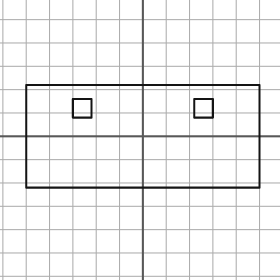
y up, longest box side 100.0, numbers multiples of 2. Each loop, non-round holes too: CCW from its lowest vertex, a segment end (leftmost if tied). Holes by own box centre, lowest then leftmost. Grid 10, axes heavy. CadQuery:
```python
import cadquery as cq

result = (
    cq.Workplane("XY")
    .moveTo(-50.0, -22.0)
    .lineTo(50.0, -22.0)
    .lineTo(50.0, 22.0)
    .lineTo(-50.0, 22.0)
    .close()
    .moveTo(-30.0, 8.0)
    .lineTo(-22.0, 8.0)
    .lineTo(-22.0, 16.0)
    .lineTo(-30.0, 16.0)
    .close()
    .moveTo(22.0, 8.0)
    .lineTo(30.0, 8.0)
    .lineTo(30.0, 16.0)
    .lineTo(22.0, 16.0)
    .close()
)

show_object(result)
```